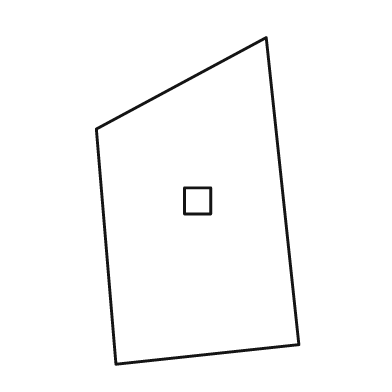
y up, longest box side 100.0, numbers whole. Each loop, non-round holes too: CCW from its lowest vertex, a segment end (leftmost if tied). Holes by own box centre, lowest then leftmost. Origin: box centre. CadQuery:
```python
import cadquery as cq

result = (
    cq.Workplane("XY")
    .moveTo(-25.0, -50.0)
    .lineTo(31.0, -44.0)
    .lineTo(21.0, 50.0)
    .lineTo(-31.0, 22.0)
    .close()
    .moveTo(-4.0, -4.0)
    .lineTo(4.0, -4.0)
    .lineTo(4.0, 4.0)
    .lineTo(-4.0, 4.0)
    .close()
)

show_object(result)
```